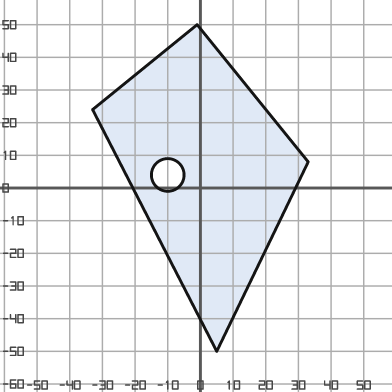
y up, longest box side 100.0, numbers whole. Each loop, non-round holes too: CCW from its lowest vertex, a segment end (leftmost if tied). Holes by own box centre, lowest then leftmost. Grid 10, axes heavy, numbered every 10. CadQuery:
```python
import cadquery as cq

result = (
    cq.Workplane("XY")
    .moveTo(5.0, -50.0)
    .lineTo(33.0, 8.0)
    .lineTo(-1.0, 50.0)
    .lineTo(-33.0, 24.0)
    .close()
    .moveTo(-10.0, 4.0)
    .circle(5.0)
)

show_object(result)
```